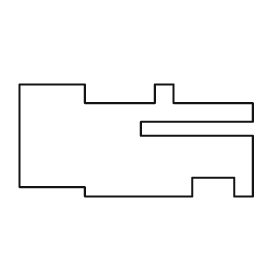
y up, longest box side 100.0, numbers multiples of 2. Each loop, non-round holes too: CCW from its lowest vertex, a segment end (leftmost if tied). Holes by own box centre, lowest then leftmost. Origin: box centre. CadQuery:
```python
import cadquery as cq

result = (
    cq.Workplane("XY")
    .moveTo(-22.0, -24.0)
    .lineTo(24.0, -24.0)
    .lineTo(24.0, -16.0)
    .lineTo(42.0, -16.0)
    .lineTo(42.0, -24.0)
    .lineTo(50.0, -24.0)
    .lineTo(50.0, 2.0)
    .lineTo(2.0, 2.0)
    .lineTo(2.0, 8.0)
    .lineTo(50.0, 8.0)
    .lineTo(50.0, 16.0)
    .lineTo(16.0, 16.0)
    .lineTo(16.0, 24.0)
    .lineTo(8.0, 24.0)
    .lineTo(8.0, 16.0)
    .lineTo(-22.0, 16.0)
    .lineTo(-22.0, 24.0)
    .lineTo(-50.0, 24.0)
    .lineTo(-50.0, -20.0)
    .lineTo(-22.0, -20.0)
    .close()
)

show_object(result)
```